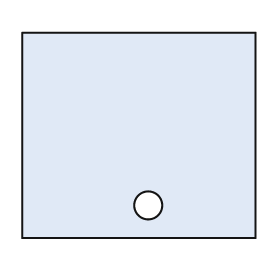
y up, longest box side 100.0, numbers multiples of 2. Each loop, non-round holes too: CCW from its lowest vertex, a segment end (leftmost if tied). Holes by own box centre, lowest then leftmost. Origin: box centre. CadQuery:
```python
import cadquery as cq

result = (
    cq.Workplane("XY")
    .moveTo(-50.0, -44.0)
    .lineTo(50.0, -44.0)
    .lineTo(50.0, 44.0)
    .lineTo(-50.0, 44.0)
    .close()
    .moveTo(4.0, -30.0)
    .circle(6.0)
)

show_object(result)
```